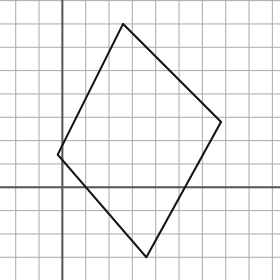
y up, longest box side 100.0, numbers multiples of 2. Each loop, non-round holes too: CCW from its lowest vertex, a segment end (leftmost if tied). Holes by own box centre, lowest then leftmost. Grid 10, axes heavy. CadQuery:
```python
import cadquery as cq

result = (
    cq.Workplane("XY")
    .moveTo(36.0, -30.0)
    .lineTo(68.0, 28.0)
    .lineTo(26.0, 70.0)
    .lineTo(-2.0, 14.0)
    .close()
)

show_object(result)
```